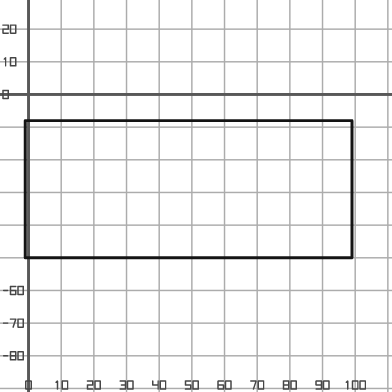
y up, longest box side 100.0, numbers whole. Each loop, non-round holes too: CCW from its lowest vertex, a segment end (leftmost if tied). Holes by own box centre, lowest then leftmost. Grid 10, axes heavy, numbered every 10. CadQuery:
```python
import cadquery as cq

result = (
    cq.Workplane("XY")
    .moveTo(-1.0, -50.0)
    .lineTo(99.0, -50.0)
    .lineTo(99.0, -8.0)
    .lineTo(-1.0, -8.0)
    .close()
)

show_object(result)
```